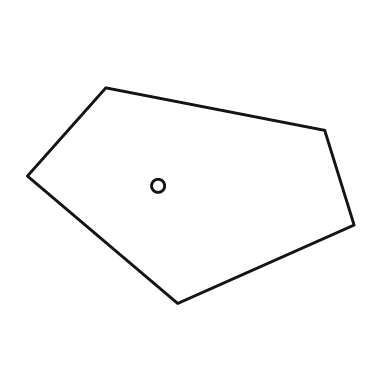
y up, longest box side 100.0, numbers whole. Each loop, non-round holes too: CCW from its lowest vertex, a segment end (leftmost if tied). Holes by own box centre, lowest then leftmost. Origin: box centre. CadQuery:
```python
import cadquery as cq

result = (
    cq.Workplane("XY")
    .moveTo(-4.0, -33.0)
    .lineTo(50.0, -9.0)
    .lineTo(41.0, 20.0)
    .lineTo(-26.0, 33.0)
    .lineTo(-50.0, 6.0)
    .close()
    .moveTo(-10.0, 3.0)
    .circle(2.0)
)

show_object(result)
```